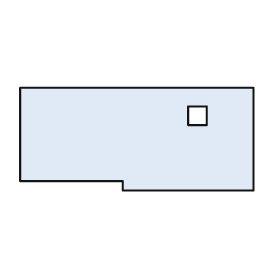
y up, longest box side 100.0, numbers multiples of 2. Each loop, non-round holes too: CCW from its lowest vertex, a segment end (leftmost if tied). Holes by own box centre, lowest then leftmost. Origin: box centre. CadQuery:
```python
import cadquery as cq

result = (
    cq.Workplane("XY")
    .moveTo(-6.0, -22.0)
    .lineTo(50.0, -22.0)
    .lineTo(50.0, 22.0)
    .lineTo(-50.0, 22.0)
    .lineTo(-50.0, -18.0)
    .lineTo(-6.0, -18.0)
    .close()
    .moveTo(22.0, 6.0)
    .lineTo(30.0, 6.0)
    .lineTo(30.0, 14.0)
    .lineTo(22.0, 14.0)
    .close()
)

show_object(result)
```